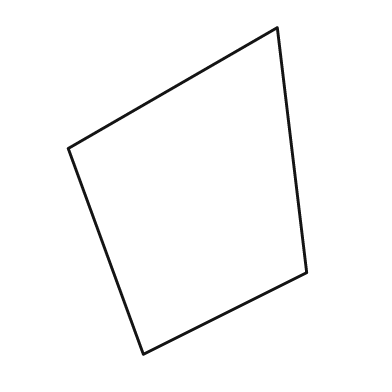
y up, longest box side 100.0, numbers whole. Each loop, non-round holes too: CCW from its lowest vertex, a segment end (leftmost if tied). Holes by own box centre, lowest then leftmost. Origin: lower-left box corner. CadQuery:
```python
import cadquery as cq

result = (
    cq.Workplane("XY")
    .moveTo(23.0, 0.0)
    .lineTo(73.0, 25.0)
    .lineTo(64.0, 100.0)
    .lineTo(0.0, 63.0)
    .close()
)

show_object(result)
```